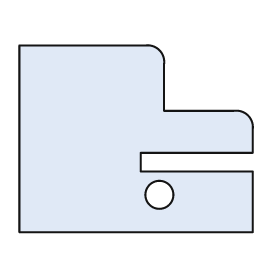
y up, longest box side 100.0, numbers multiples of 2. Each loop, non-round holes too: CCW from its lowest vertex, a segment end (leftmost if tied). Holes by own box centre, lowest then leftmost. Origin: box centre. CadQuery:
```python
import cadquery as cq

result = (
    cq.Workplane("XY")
    .moveTo(-50.0, -40.0)
    .lineTo(50.0, -40.0)
    .lineTo(50.0, -14.0)
    .lineTo(2.0, -14.0)
    .lineTo(2.0, -6.0)
    .lineTo(50.0, -6.0)
    .lineTo(50.0, 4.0)
    .threePointArc((48.0, 10.0), (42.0, 12.0))
    .lineTo(12.0, 12.0)
    .lineTo(12.0, 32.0)
    .threePointArc((10.0, 38.0), (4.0, 40.0))
    .lineTo(-50.0, 40.0)
    .close()
    .moveTo(10.0, -24.0)
    .circle(6.0)
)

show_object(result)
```